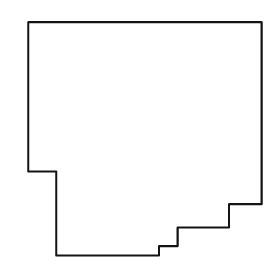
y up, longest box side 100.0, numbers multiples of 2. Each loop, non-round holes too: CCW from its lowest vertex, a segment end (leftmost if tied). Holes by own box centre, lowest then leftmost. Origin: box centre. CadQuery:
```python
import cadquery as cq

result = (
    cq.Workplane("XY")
    .moveTo(-38.0, -50.0)
    .lineTo(6.0, -50.0)
    .lineTo(6.0, -46.0)
    .lineTo(14.0, -46.0)
    .lineTo(14.0, -38.0)
    .lineTo(36.0, -38.0)
    .lineTo(36.0, -28.0)
    .lineTo(50.0, -28.0)
    .lineTo(50.0, 50.0)
    .lineTo(-50.0, 50.0)
    .lineTo(-50.0, -14.0)
    .lineTo(-38.0, -14.0)
    .close()
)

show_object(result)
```